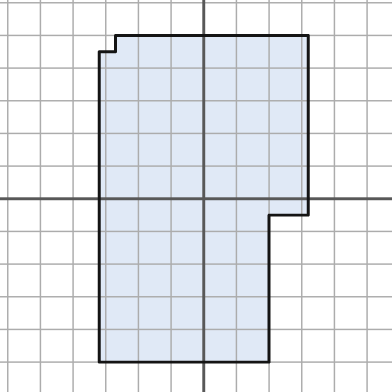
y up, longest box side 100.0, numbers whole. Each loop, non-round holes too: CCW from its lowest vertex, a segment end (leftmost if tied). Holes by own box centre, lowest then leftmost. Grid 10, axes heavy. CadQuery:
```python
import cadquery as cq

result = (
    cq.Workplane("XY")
    .moveTo(-32.0, -50.0)
    .lineTo(20.0, -50.0)
    .lineTo(20.0, -5.0)
    .lineTo(32.0, -5.0)
    .lineTo(32.0, 50.0)
    .lineTo(-27.0, 50.0)
    .lineTo(-27.0, 45.0)
    .lineTo(-32.0, 45.0)
    .close()
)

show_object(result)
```